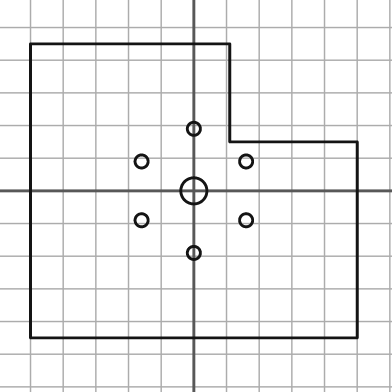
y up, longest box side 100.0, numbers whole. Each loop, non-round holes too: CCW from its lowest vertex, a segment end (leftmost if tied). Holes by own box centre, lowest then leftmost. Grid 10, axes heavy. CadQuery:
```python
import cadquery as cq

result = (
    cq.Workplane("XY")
    .moveTo(-50.0, -45.0)
    .lineTo(50.0, -45.0)
    .lineTo(50.0, 15.0)
    .lineTo(11.0, 15.0)
    .lineTo(11.0, 45.0)
    .lineTo(-50.0, 45.0)
    .close()
    .moveTo(0.0, -19.0)
    .circle(2.0)
    .moveTo(-16.0, -9.0)
    .circle(2.0)
    .moveTo(16.0, -9.0)
    .circle(2.0)
    .moveTo(0.0, 0.0)
    .circle(4.0)
    .moveTo(-16.0, 9.0)
    .circle(2.0)
    .moveTo(16.0, 9.0)
    .circle(2.0)
    .moveTo(0.0, 19.0)
    .circle(2.0)
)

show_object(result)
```